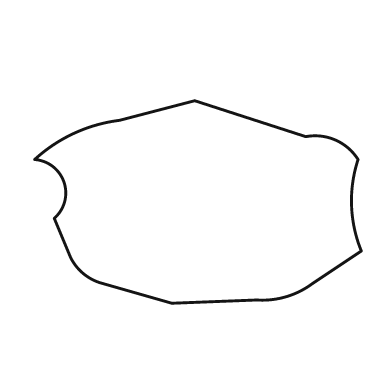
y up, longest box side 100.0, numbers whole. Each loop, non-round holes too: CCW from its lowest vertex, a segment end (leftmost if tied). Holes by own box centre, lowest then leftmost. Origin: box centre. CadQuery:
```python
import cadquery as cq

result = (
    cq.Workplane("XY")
    .moveTo(-8.0, -31.0)
    .lineTo(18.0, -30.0)
    .threePointArc((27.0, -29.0), (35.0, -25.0))
    .lineTo(50.0, -15.0)
    .threePointArc((47.0, -1.0), (49.0, 13.0))
    .threePointArc((42.0, 19.0), (33.0, 20.0))
    .lineTo(-1.0, 31.0)
    .lineTo(-24.0, 25.0)
    .threePointArc((-38.0, 21.0), (-50.0, 13.0))
    .threePointArc((-41.0, 6.0), (-44.0, -5.0))
    .lineTo(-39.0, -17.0)
    .threePointArc((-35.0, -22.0), (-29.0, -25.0))
    .close()
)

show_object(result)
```